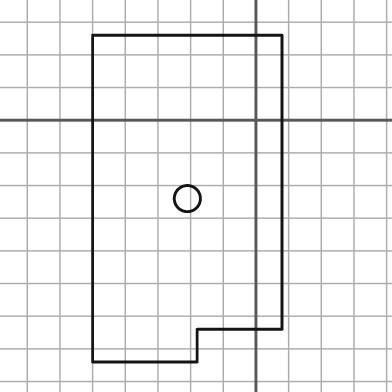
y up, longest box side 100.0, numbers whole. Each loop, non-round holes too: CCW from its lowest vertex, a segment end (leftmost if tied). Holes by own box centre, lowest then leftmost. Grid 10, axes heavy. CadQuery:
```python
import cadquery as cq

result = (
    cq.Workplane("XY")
    .moveTo(-50.0, -74.0)
    .lineTo(-18.0, -74.0)
    .lineTo(-18.0, -64.0)
    .lineTo(8.0, -64.0)
    .lineTo(8.0, 26.0)
    .lineTo(-50.0, 26.0)
    .close()
    .moveTo(-21.0, -24.0)
    .circle(4.0)
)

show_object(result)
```